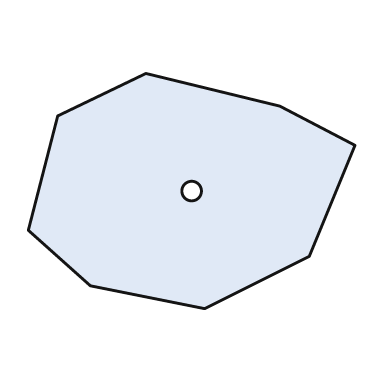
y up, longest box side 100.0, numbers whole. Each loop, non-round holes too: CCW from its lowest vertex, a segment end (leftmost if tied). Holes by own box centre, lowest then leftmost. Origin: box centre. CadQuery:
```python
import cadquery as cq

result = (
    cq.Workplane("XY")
    .moveTo(4.0, -36.0)
    .lineTo(36.0, -20.0)
    .lineTo(50.0, 14.0)
    .lineTo(27.0, 26.0)
    .lineTo(-14.0, 36.0)
    .lineTo(-41.0, 23.0)
    .lineTo(-50.0, -12.0)
    .lineTo(-31.0, -29.0)
    .close()
    .moveTo(0.0, 0.0)
    .circle(3.0)
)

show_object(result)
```